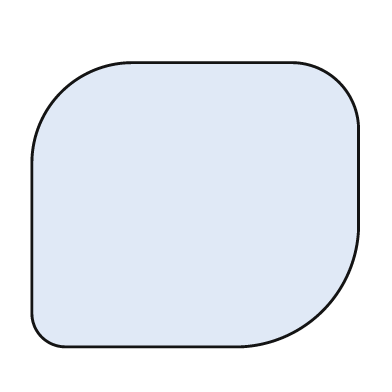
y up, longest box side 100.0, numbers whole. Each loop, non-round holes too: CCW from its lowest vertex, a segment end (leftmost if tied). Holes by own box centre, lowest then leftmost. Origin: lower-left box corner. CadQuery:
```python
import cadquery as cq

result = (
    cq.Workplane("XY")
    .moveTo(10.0, 0.0)
    .lineTo(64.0, 0.0)
    .threePointArc((89.0, 11.0), (100.0, 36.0))
    .lineTo(100.0, 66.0)
    .threePointArc((94.0, 81.0), (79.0, 87.0))
    .lineTo(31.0, 87.0)
    .threePointArc((9.0, 78.0), (0.0, 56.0))
    .lineTo(0.0, 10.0)
    .threePointArc((3.0, 3.0), (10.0, 0.0))
    .close()
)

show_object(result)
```